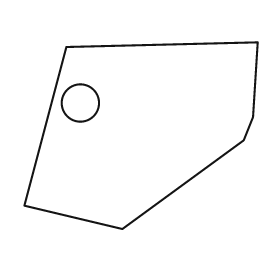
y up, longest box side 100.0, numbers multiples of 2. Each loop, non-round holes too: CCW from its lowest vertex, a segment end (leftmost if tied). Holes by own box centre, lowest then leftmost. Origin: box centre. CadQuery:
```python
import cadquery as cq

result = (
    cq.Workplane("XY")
    .moveTo(-8.0, -40.0)
    .lineTo(44.0, -2.0)
    .lineTo(48.0, 8.0)
    .lineTo(50.0, 40.0)
    .lineTo(-32.0, 38.0)
    .lineTo(-50.0, -30.0)
    .close()
    .moveTo(-26.0, 14.0)
    .circle(8.0)
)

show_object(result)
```